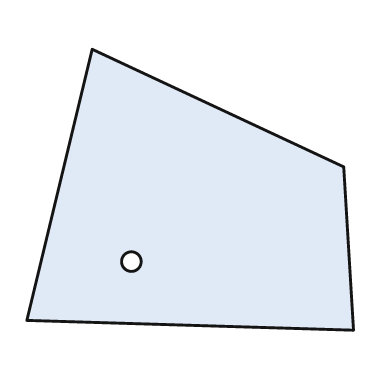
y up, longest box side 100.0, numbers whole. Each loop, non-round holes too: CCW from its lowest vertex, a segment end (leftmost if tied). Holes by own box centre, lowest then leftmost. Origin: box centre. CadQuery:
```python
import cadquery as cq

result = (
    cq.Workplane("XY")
    .moveTo(50.0, -43.0)
    .lineTo(47.0, 7.0)
    .lineTo(-30.0, 43.0)
    .lineTo(-50.0, -40.0)
    .close()
    .moveTo(-18.0, -22.0)
    .circle(3.0)
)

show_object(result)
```